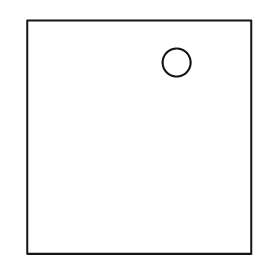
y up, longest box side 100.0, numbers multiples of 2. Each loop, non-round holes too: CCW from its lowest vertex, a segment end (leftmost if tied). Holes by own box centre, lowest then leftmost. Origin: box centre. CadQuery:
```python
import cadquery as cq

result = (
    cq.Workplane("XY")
    .moveTo(-48.0, -50.0)
    .lineTo(48.0, -50.0)
    .lineTo(48.0, 50.0)
    .lineTo(-48.0, 50.0)
    .close()
    .moveTo(16.0, 32.0)
    .circle(6.0)
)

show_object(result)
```